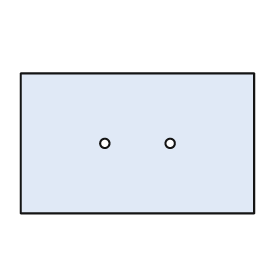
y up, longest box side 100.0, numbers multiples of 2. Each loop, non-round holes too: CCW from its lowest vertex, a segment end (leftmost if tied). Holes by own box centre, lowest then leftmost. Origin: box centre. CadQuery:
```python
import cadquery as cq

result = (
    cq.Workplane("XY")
    .moveTo(-50.0, -30.0)
    .lineTo(50.0, -30.0)
    .lineTo(50.0, 30.0)
    .lineTo(-50.0, 30.0)
    .close()
    .moveTo(-14.0, 0.0)
    .circle(2.0)
    .moveTo(14.0, 0.0)
    .circle(2.0)
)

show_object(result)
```